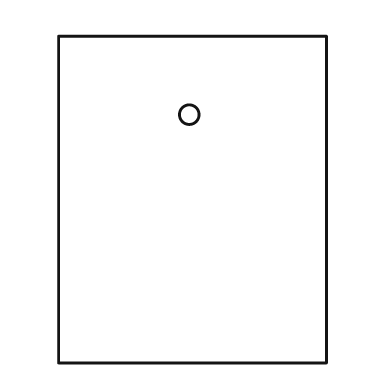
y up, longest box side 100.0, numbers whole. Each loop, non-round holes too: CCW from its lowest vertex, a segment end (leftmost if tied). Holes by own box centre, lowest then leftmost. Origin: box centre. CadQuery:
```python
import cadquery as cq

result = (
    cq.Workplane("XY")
    .moveTo(-41.0, -50.0)
    .lineTo(41.0, -50.0)
    .lineTo(41.0, 50.0)
    .lineTo(-41.0, 50.0)
    .close()
    .moveTo(-1.0, 26.0)
    .circle(3.0)
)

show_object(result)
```